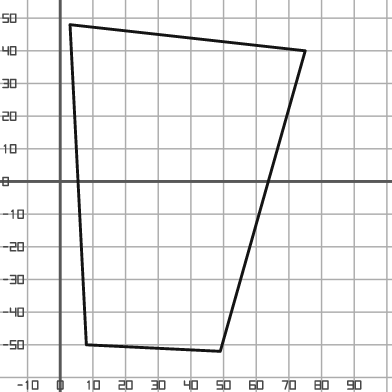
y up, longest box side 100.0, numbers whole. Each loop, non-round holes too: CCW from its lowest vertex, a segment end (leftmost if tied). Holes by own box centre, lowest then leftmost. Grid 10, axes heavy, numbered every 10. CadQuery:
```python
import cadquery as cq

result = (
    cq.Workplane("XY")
    .moveTo(49.0, -52.0)
    .lineTo(75.0, 40.0)
    .lineTo(3.0, 48.0)
    .lineTo(8.0, -50.0)
    .close()
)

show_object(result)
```